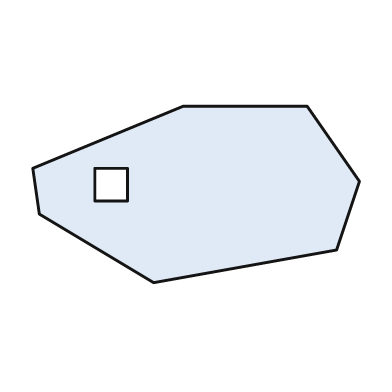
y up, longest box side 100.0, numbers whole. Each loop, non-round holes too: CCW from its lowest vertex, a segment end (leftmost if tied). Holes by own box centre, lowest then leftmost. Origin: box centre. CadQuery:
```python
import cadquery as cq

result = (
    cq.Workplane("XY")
    .moveTo(-13.0, -27.0)
    .lineTo(43.0, -17.0)
    .lineTo(50.0, 4.0)
    .lineTo(34.0, 27.0)
    .lineTo(-4.0, 27.0)
    .lineTo(-50.0, 8.0)
    .lineTo(-48.0, -6.0)
    .close()
    .moveTo(-31.0, -2.0)
    .lineTo(-21.0, -2.0)
    .lineTo(-21.0, 8.0)
    .lineTo(-31.0, 8.0)
    .close()
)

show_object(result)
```